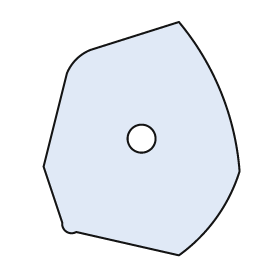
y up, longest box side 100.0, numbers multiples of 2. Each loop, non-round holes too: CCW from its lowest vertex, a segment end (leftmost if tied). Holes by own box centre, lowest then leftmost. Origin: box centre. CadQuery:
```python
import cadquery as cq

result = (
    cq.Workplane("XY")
    .moveTo(16.0, -50.0)
    .threePointArc((32.0, -34.0), (42.0, -14.0))
    .threePointArc((34.0, 20.0), (16.0, 50.0))
    .lineTo(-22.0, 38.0)
    .threePointArc((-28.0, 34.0), (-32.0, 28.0))
    .lineTo(-42.0, -12.0)
    .lineTo(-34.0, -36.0)
    .threePointArc((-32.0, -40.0), (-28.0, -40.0))
    .close()
    .moveTo(0.0, 0.0)
    .circle(6.0)
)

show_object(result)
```